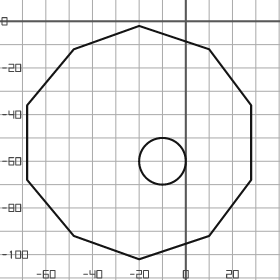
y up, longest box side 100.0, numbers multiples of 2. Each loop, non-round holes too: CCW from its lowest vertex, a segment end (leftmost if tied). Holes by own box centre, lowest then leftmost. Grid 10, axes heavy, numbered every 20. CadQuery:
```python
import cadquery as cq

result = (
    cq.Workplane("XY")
    .moveTo(-20.0, -102.0)
    .lineTo(10.0, -92.0)
    .lineTo(28.0, -68.0)
    .lineTo(28.0, -36.0)
    .lineTo(10.0, -12.0)
    .lineTo(-20.0, -2.0)
    .lineTo(-48.0, -12.0)
    .lineTo(-68.0, -36.0)
    .lineTo(-68.0, -68.0)
    .lineTo(-48.0, -92.0)
    .close()
    .moveTo(-10.0, -60.0)
    .circle(10.0)
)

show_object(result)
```